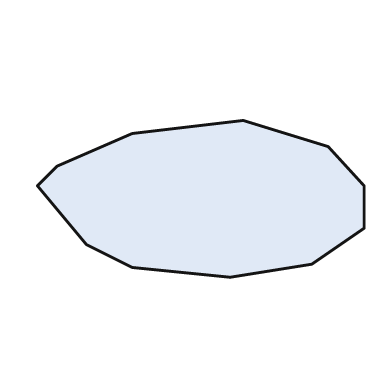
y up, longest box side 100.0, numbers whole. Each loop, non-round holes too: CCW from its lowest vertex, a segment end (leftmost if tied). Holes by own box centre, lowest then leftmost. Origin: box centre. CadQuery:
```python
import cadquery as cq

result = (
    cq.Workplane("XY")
    .moveTo(9.0, -24.0)
    .lineTo(34.0, -20.0)
    .lineTo(50.0, -9.0)
    .lineTo(50.0, 4.0)
    .lineTo(39.0, 16.0)
    .lineTo(13.0, 24.0)
    .lineTo(-21.0, 20.0)
    .lineTo(-44.0, 10.0)
    .lineTo(-50.0, 4.0)
    .lineTo(-35.0, -14.0)
    .lineTo(-21.0, -21.0)
    .close()
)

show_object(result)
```